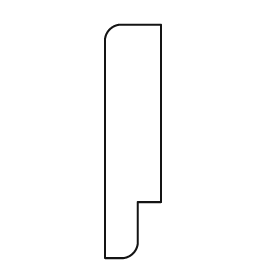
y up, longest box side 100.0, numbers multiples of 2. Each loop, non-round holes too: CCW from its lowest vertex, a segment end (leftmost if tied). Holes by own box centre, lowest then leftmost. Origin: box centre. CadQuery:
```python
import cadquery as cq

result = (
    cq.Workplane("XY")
    .moveTo(-12.0, -50.0)
    .lineTo(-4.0, -50.0)
    .threePointArc((0.0, -48.0), (2.0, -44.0))
    .lineTo(2.0, -26.0)
    .lineTo(12.0, -26.0)
    .lineTo(12.0, 50.0)
    .lineTo(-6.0, 50.0)
    .threePointArc((-10.0, 48.0), (-12.0, 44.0))
    .close()
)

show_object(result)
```